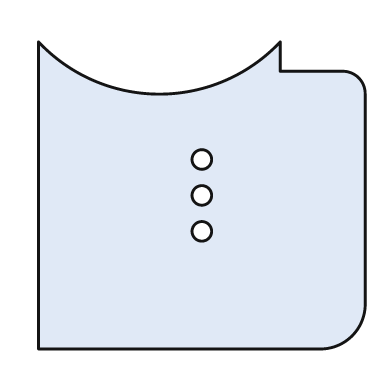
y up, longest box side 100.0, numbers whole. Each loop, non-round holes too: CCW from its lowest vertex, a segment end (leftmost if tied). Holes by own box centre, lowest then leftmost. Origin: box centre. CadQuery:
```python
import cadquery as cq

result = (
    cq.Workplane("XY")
    .moveTo(-50.0, -47.0)
    .lineTo(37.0, -47.0)
    .threePointArc((46.0, -43.0), (50.0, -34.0))
    .lineTo(50.0, 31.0)
    .threePointArc((48.0, 36.0), (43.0, 38.0))
    .lineTo(24.0, 38.0)
    .lineTo(24.0, 47.0)
    .threePointArc((-13.0, 31.0), (-50.0, 47.0))
    .close()
    .moveTo(0.0, -11.0)
    .circle(3.0)
    .moveTo(0.0, 0.0)
    .circle(3.0)
    .moveTo(0.0, 11.0)
    .circle(3.0)
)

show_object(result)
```